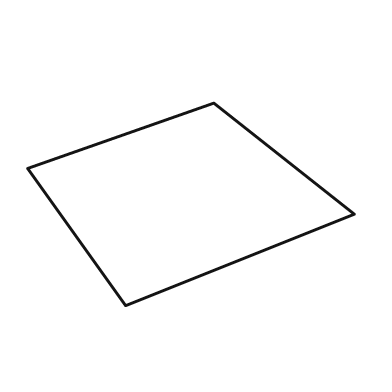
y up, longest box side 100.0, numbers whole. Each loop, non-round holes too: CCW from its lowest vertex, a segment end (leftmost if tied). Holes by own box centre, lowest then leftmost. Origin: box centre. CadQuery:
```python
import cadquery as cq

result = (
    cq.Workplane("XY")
    .moveTo(-20.0, -31.0)
    .lineTo(50.0, -3.0)
    .lineTo(7.0, 31.0)
    .lineTo(-50.0, 11.0)
    .close()
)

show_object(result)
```